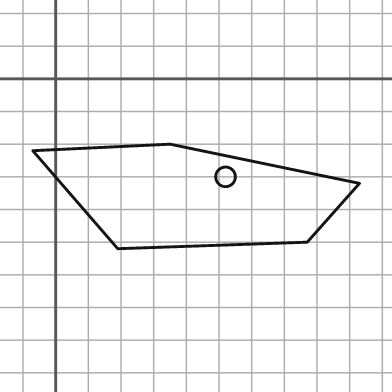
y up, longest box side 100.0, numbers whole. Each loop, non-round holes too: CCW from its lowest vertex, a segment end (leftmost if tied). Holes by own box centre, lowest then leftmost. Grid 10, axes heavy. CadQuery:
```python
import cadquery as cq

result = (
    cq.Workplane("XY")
    .moveTo(19.0, -52.0)
    .lineTo(77.0, -50.0)
    .lineTo(93.0, -32.0)
    .lineTo(35.0, -20.0)
    .lineTo(-7.0, -22.0)
    .close()
    .moveTo(52.0, -30.0)
    .circle(3.0)
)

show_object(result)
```